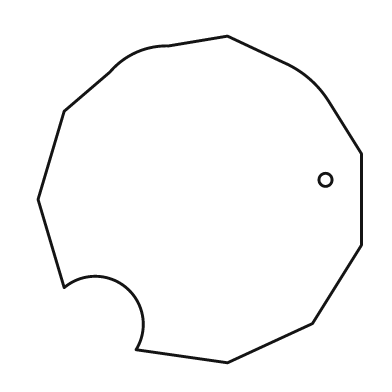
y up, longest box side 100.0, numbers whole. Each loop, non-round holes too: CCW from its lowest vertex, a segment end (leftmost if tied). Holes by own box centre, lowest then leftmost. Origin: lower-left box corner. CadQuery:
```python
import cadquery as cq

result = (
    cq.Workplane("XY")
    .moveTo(58.0, 0.0)
    .lineTo(84.0, 12.0)
    .lineTo(99.0, 36.0)
    .lineTo(99.0, 64.0)
    .lineTo(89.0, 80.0)
    .threePointArc((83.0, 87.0), (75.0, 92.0))
    .lineTo(58.0, 100.0)
    .lineTo(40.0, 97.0)
    .threePointArc((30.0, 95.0), (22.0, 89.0))
    .lineTo(8.0, 77.0)
    .lineTo(0.0, 50.0)
    .lineTo(8.0, 23.0)
    .threePointArc((27.0, 23.0), (30.0, 4.0))
    .close()
    .moveTo(88.0, 56.0)
    .circle(2.0)
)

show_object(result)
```